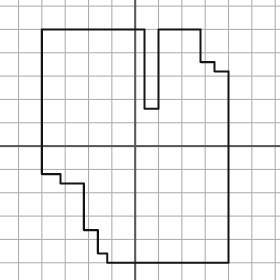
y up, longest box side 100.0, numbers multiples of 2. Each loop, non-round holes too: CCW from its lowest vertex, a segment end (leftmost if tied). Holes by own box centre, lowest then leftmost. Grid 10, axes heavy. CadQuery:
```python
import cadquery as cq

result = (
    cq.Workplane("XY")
    .moveTo(-12.0, -50.0)
    .lineTo(40.0, -50.0)
    .lineTo(40.0, 32.0)
    .lineTo(34.0, 32.0)
    .lineTo(34.0, 36.0)
    .lineTo(28.0, 36.0)
    .lineTo(28.0, 50.0)
    .lineTo(10.0, 50.0)
    .lineTo(10.0, 16.0)
    .lineTo(4.0, 16.0)
    .lineTo(4.0, 50.0)
    .lineTo(-40.0, 50.0)
    .lineTo(-40.0, -12.0)
    .lineTo(-32.0, -12.0)
    .lineTo(-32.0, -16.0)
    .lineTo(-22.0, -16.0)
    .lineTo(-22.0, -36.0)
    .lineTo(-16.0, -36.0)
    .lineTo(-16.0, -46.0)
    .lineTo(-12.0, -46.0)
    .close()
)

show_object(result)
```